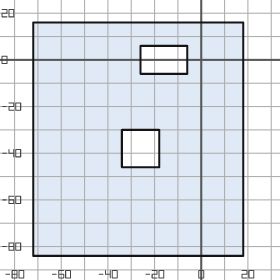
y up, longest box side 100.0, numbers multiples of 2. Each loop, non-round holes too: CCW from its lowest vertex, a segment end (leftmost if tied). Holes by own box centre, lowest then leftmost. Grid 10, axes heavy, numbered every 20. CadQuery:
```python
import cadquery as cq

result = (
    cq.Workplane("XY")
    .moveTo(-72.0, -84.0)
    .lineTo(18.0, -84.0)
    .lineTo(18.0, 16.0)
    .lineTo(-72.0, 16.0)
    .close()
    .moveTo(-34.0, -46.0)
    .lineTo(-18.0, -46.0)
    .lineTo(-18.0, -30.0)
    .lineTo(-34.0, -30.0)
    .close()
    .moveTo(-26.0, -6.0)
    .lineTo(-6.0, -6.0)
    .lineTo(-6.0, 6.0)
    .lineTo(-26.0, 6.0)
    .close()
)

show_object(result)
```